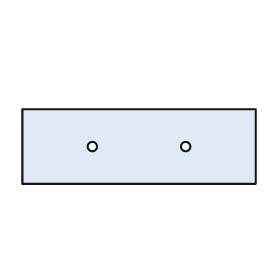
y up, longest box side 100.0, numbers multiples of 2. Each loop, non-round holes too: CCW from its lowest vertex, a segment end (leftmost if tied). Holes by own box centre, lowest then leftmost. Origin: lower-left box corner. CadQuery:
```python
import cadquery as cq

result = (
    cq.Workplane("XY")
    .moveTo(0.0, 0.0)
    .lineTo(100.0, 0.0)
    .lineTo(100.0, 32.0)
    .lineTo(0.0, 32.0)
    .close()
    .moveTo(30.0, 16.0)
    .circle(2.0)
    .moveTo(70.0, 16.0)
    .circle(2.0)
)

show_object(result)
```